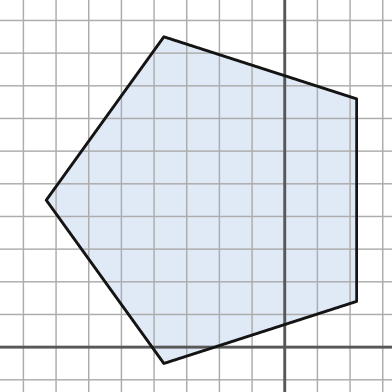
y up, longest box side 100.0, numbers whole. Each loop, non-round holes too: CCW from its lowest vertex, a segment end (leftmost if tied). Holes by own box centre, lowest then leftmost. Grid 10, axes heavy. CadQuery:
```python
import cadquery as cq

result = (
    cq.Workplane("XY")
    .moveTo(-37.0, -5.0)
    .lineTo(22.0, 14.0)
    .lineTo(22.0, 76.0)
    .lineTo(-37.0, 95.0)
    .lineTo(-73.0, 45.0)
    .close()
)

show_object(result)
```